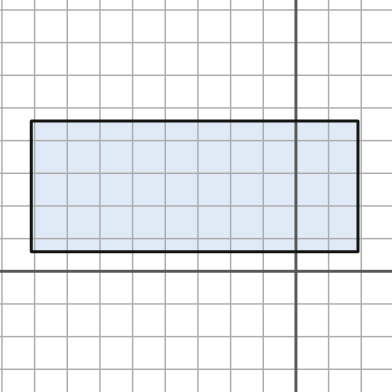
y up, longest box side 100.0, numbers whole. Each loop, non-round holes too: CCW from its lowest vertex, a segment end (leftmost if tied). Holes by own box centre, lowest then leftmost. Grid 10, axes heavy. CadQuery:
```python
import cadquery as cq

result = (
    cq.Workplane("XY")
    .moveTo(-81.0, 6.0)
    .lineTo(19.0, 6.0)
    .lineTo(19.0, 46.0)
    .lineTo(-81.0, 46.0)
    .close()
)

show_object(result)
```